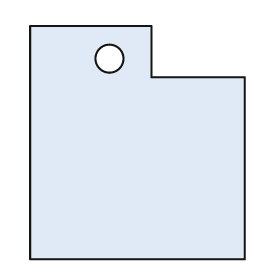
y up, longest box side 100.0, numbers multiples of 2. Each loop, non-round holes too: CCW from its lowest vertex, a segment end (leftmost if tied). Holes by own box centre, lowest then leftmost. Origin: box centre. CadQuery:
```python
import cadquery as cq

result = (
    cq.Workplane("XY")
    .moveTo(-46.0, -50.0)
    .lineTo(46.0, -50.0)
    .lineTo(46.0, 28.0)
    .lineTo(6.0, 28.0)
    .lineTo(6.0, 50.0)
    .lineTo(-46.0, 50.0)
    .close()
    .moveTo(-12.0, 36.0)
    .circle(6.0)
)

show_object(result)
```